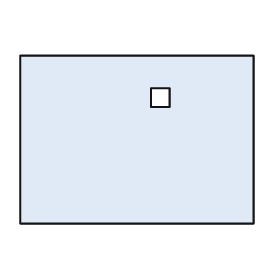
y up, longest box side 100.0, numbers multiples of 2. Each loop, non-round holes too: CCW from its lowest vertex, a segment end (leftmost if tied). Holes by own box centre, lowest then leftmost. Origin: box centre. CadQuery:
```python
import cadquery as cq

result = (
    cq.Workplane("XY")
    .moveTo(-50.0, -36.0)
    .lineTo(50.0, -36.0)
    .lineTo(50.0, 36.0)
    .lineTo(-50.0, 36.0)
    .close()
    .moveTo(6.0, 14.0)
    .lineTo(14.0, 14.0)
    .lineTo(14.0, 22.0)
    .lineTo(6.0, 22.0)
    .close()
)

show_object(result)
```